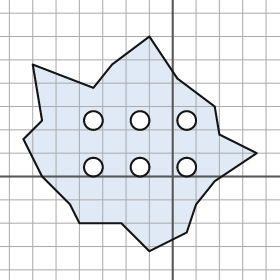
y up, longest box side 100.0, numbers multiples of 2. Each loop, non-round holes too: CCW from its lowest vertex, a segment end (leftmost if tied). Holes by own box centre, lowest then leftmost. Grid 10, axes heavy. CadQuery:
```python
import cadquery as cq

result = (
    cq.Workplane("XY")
    .moveTo(-10.0, -32.0)
    .lineTo(6.0, -24.0)
    .lineTo(10.0, -12.0)
    .lineTo(18.0, -2.0)
    .lineTo(36.0, 10.0)
    .lineTo(20.0, 18.0)
    .lineTo(18.0, 30.0)
    .lineTo(2.0, 42.0)
    .lineTo(-10.0, 60.0)
    .lineTo(-26.0, 48.0)
    .lineTo(-34.0, 38.0)
    .lineTo(-60.0, 48.0)
    .lineTo(-56.0, 24.0)
    .lineTo(-64.0, 16.0)
    .lineTo(-56.0, 0.0)
    .lineTo(-44.0, -12.0)
    .lineTo(-40.0, -20.0)
    .lineTo(-22.0, -20.0)
    .close()
    .moveTo(-34.0, 4.0)
    .circle(4.0)
    .moveTo(-14.0, 4.0)
    .circle(4.0)
    .moveTo(6.0, 4.0)
    .circle(4.0)
    .moveTo(-34.0, 24.0)
    .circle(4.0)
    .moveTo(-14.0, 24.0)
    .circle(4.0)
    .moveTo(6.0, 24.0)
    .circle(4.0)
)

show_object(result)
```